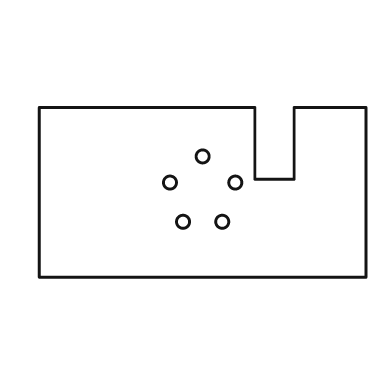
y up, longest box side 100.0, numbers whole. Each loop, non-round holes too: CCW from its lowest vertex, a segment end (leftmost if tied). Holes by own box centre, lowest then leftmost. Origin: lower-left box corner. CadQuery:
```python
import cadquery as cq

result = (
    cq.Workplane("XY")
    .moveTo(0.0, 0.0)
    .lineTo(100.0, 0.0)
    .lineTo(100.0, 52.0)
    .lineTo(78.0, 52.0)
    .lineTo(78.0, 30.0)
    .lineTo(66.0, 30.0)
    .lineTo(66.0, 52.0)
    .lineTo(0.0, 52.0)
    .close()
    .moveTo(44.0, 17.0)
    .circle(2.0)
    .moveTo(56.0, 17.0)
    .circle(2.0)
    .moveTo(40.0, 29.0)
    .circle(2.0)
    .moveTo(60.0, 29.0)
    .circle(2.0)
    .moveTo(50.0, 37.0)
    .circle(2.0)
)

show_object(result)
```